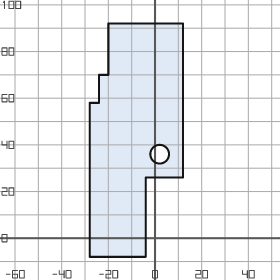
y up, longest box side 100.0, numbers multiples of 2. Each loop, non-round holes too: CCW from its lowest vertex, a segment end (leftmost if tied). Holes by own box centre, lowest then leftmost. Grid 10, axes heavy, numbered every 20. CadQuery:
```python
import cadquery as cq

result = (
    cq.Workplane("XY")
    .moveTo(-28.0, -8.0)
    .lineTo(-4.0, -8.0)
    .lineTo(-4.0, 26.0)
    .lineTo(12.0, 26.0)
    .lineTo(12.0, 92.0)
    .lineTo(-20.0, 92.0)
    .lineTo(-20.0, 70.0)
    .lineTo(-24.0, 70.0)
    .lineTo(-24.0, 58.0)
    .lineTo(-28.0, 58.0)
    .close()
    .moveTo(2.0, 36.0)
    .circle(4.0)
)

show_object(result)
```